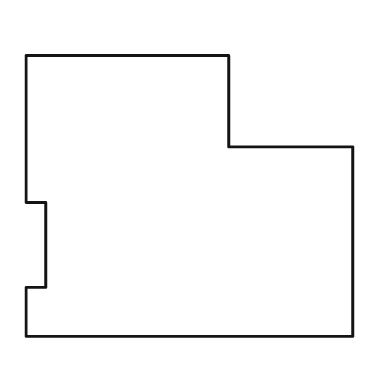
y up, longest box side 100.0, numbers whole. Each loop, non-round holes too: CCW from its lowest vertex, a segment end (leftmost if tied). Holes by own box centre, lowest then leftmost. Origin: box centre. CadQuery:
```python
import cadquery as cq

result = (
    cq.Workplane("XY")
    .moveTo(-50.0, -43.0)
    .lineTo(50.0, -43.0)
    .lineTo(50.0, 15.0)
    .lineTo(12.0, 15.0)
    .lineTo(12.0, 43.0)
    .lineTo(-50.0, 43.0)
    .lineTo(-50.0, -2.0)
    .lineTo(-44.0, -2.0)
    .lineTo(-44.0, -28.0)
    .lineTo(-50.0, -28.0)
    .close()
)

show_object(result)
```